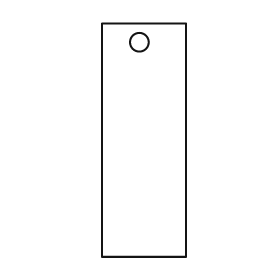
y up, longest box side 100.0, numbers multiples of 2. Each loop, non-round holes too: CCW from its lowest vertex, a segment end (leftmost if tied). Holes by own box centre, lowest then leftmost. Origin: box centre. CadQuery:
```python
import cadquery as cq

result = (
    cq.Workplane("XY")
    .moveTo(-18.0, -50.0)
    .lineTo(18.0, -50.0)
    .lineTo(18.0, 50.0)
    .lineTo(-18.0, 50.0)
    .close()
    .moveTo(-2.0, 42.0)
    .circle(4.0)
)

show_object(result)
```